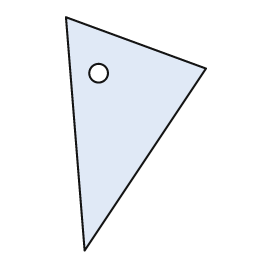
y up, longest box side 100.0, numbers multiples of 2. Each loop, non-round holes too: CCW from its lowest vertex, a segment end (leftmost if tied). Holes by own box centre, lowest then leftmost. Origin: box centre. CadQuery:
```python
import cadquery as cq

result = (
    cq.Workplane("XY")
    .moveTo(-22.0, -50.0)
    .lineTo(30.0, 28.0)
    .lineTo(-30.0, 50.0)
    .close()
    .moveTo(-16.0, 26.0)
    .circle(4.0)
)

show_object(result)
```